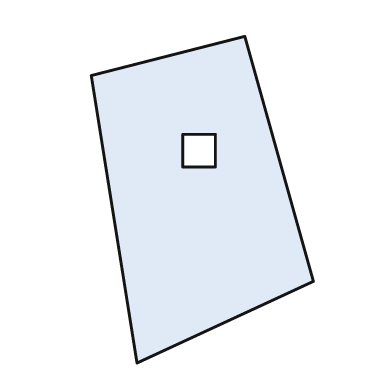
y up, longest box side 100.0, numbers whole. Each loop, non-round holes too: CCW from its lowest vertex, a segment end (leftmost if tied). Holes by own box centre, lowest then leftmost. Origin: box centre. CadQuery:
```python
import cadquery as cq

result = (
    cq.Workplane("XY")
    .moveTo(-20.0, -50.0)
    .lineTo(34.0, -25.0)
    .lineTo(13.0, 50.0)
    .lineTo(-34.0, 38.0)
    .close()
    .moveTo(-6.0, 10.0)
    .lineTo(4.0, 10.0)
    .lineTo(4.0, 20.0)
    .lineTo(-6.0, 20.0)
    .close()
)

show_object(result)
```